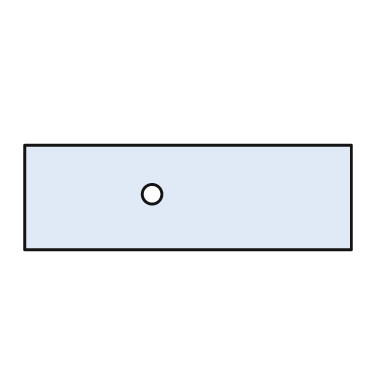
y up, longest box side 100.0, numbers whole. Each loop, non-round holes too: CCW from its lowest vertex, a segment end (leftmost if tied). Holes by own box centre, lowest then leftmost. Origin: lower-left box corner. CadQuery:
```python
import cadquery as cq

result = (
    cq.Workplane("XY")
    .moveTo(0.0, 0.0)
    .lineTo(100.0, 0.0)
    .lineTo(100.0, 32.0)
    .lineTo(0.0, 32.0)
    .close()
    .moveTo(39.0, 17.0)
    .circle(3.0)
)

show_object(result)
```